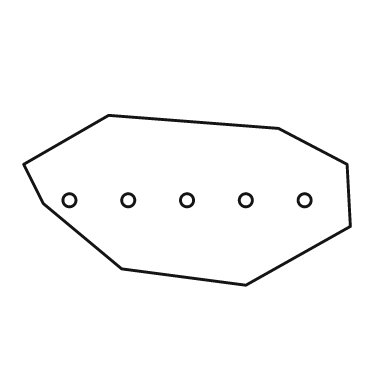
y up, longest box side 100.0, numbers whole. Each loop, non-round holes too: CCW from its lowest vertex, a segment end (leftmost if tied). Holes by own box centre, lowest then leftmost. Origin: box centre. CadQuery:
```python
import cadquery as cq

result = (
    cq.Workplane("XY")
    .moveTo(18.0, -26.0)
    .lineTo(50.0, -8.0)
    .lineTo(49.0, 11.0)
    .lineTo(28.0, 22.0)
    .lineTo(-24.0, 26.0)
    .lineTo(-50.0, 11.0)
    .lineTo(-44.0, -1.0)
    .lineTo(-20.0, -21.0)
    .close()
    .moveTo(-36.0, 0.0)
    .circle(2.0)
    .moveTo(-18.0, 0.0)
    .circle(2.0)
    .moveTo(0.0, 0.0)
    .circle(2.0)
    .moveTo(18.0, 0.0)
    .circle(2.0)
    .moveTo(36.0, 0.0)
    .circle(2.0)
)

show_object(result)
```